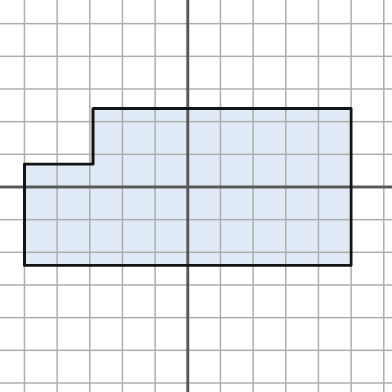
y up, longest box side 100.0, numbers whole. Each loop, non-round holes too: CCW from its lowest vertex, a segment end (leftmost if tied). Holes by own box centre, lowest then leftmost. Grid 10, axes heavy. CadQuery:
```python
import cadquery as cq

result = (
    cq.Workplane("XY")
    .moveTo(-50.0, -24.0)
    .lineTo(50.0, -24.0)
    .lineTo(50.0, 24.0)
    .lineTo(-29.0, 24.0)
    .lineTo(-29.0, 7.0)
    .lineTo(-50.0, 7.0)
    .close()
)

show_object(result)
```